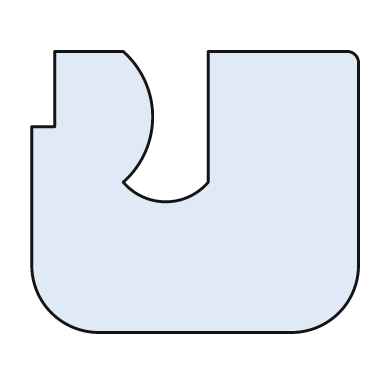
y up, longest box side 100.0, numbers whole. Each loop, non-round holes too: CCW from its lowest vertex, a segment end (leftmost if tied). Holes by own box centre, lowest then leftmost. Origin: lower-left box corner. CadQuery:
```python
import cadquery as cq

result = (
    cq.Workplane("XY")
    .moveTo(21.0, 0.0)
    .lineTo(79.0, 0.0)
    .threePointArc((94.0, 6.0), (100.0, 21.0))
    .lineTo(100.0, 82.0)
    .threePointArc((99.0, 85.0), (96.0, 86.0))
    .lineTo(54.0, 86.0)
    .lineTo(54.0, 46.0)
    .threePointArc((41.0, 40.0), (28.0, 46.0))
    .threePointArc((37.0, 66.0), (28.0, 86.0))
    .lineTo(7.0, 86.0)
    .lineTo(7.0, 63.0)
    .lineTo(0.0, 63.0)
    .lineTo(0.0, 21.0)
    .threePointArc((6.0, 6.0), (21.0, 0.0))
    .close()
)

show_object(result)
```